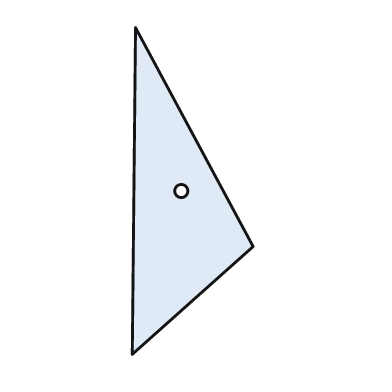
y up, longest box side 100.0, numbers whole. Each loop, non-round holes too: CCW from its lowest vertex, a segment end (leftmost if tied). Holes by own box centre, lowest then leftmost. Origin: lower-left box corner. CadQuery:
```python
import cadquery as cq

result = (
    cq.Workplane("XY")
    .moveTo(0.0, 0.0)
    .lineTo(37.0, 33.0)
    .lineTo(1.0, 100.0)
    .close()
    .moveTo(15.0, 50.0)
    .circle(2.0)
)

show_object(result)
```